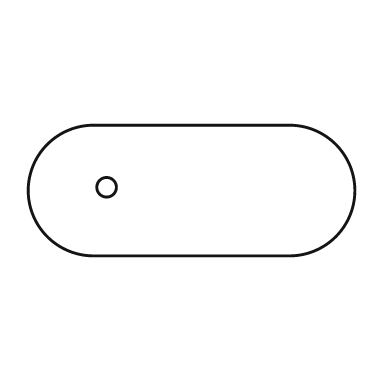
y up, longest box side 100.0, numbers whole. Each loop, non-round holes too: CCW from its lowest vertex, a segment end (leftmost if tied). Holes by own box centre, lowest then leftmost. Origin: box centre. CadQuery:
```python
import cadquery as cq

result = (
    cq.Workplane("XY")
    .moveTo(-30.0, -20.0)
    .lineTo(30.0, -20.0)
    .threePointArc((50.0, 0.0), (30.0, 20.0))
    .lineTo(-30.0, 20.0)
    .threePointArc((-50.0, 0.0), (-30.0, -20.0))
    .close()
    .moveTo(-26.0, 1.0)
    .circle(3.0)
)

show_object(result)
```